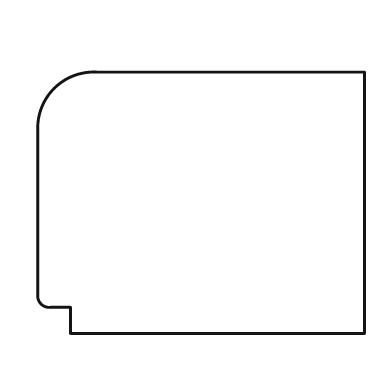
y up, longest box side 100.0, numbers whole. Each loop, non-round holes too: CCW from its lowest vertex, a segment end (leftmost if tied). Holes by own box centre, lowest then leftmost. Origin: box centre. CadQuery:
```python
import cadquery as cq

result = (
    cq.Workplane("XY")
    .moveTo(-40.0, -40.0)
    .lineTo(50.0, -40.0)
    .lineTo(50.0, 40.0)
    .lineTo(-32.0, 40.0)
    .threePointArc((-45.0, 35.0), (-50.0, 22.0))
    .lineTo(-50.0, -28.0)
    .threePointArc((-49.0, -31.0), (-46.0, -32.0))
    .lineTo(-40.0, -32.0)
    .close()
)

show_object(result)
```